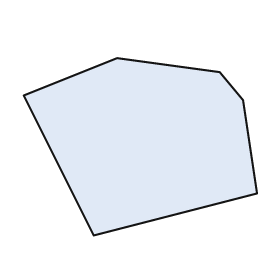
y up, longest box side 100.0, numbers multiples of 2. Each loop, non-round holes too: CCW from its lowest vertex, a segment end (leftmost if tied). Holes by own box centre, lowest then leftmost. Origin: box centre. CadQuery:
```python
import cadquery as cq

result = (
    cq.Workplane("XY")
    .moveTo(-20.0, -38.0)
    .lineTo(50.0, -20.0)
    .lineTo(44.0, 20.0)
    .lineTo(34.0, 32.0)
    .lineTo(-10.0, 38.0)
    .lineTo(-50.0, 22.0)
    .close()
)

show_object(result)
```